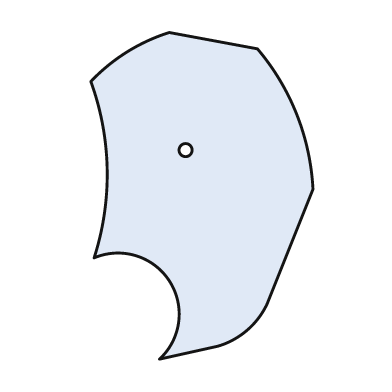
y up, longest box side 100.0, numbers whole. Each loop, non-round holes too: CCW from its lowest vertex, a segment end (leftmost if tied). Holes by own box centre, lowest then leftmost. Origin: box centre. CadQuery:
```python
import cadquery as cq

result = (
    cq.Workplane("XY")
    .moveTo(-13.0, -50.0)
    .lineTo(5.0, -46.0)
    .threePointArc((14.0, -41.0), (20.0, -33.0))
    .lineTo(34.0, 2.0)
    .threePointArc((29.0, 25.0), (17.0, 45.0))
    .lineTo(-10.0, 50.0)
    .threePointArc((-23.0, 44.0), (-34.0, 35.0))
    .threePointArc((-29.0, 8.0), (-33.0, -19.0))
    .threePointArc((-10.0, -26.0), (-13.0, -50.0))
    .close()
    .moveTo(-5.0, 14.0)
    .circle(2.0)
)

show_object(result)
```